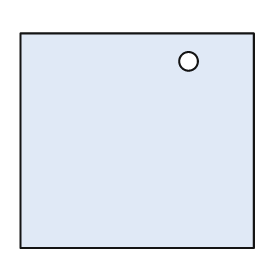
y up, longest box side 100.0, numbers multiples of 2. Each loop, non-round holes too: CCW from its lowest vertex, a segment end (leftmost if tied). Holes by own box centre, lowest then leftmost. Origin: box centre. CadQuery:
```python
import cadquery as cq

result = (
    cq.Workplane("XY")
    .moveTo(-50.0, -46.0)
    .lineTo(50.0, -46.0)
    .lineTo(50.0, 46.0)
    .lineTo(-50.0, 46.0)
    .close()
    .moveTo(22.0, 34.0)
    .circle(4.0)
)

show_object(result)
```